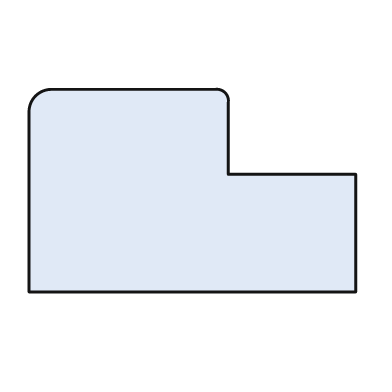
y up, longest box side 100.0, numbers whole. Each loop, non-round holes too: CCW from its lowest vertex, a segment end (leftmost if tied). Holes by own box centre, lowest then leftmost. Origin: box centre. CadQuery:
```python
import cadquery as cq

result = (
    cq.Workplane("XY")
    .moveTo(-50.0, -31.0)
    .lineTo(50.0, -31.0)
    .lineTo(50.0, 5.0)
    .lineTo(11.0, 5.0)
    .lineTo(11.0, 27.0)
    .threePointArc((10.0, 30.0), (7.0, 31.0))
    .lineTo(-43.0, 31.0)
    .threePointArc((-48.0, 29.0), (-50.0, 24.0))
    .close()
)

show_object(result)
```